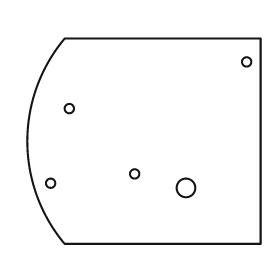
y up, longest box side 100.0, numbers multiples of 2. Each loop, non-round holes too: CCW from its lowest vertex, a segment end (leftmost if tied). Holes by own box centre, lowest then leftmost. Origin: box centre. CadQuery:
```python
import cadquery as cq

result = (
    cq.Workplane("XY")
    .moveTo(-34.0, -44.0)
    .lineTo(50.0, -44.0)
    .lineTo(50.0, 44.0)
    .lineTo(-34.0, 44.0)
    .threePointArc((-50.0, 0.0), (-34.0, -44.0))
    .close()
    .moveTo(18.0, -20.0)
    .circle(4.0)
    .moveTo(-40.0, -18.0)
    .circle(2.0)
    .moveTo(-4.0, -14.0)
    .circle(2.0)
    .moveTo(-32.0, 14.0)
    .circle(2.0)
    .moveTo(44.0, 34.0)
    .circle(2.0)
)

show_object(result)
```